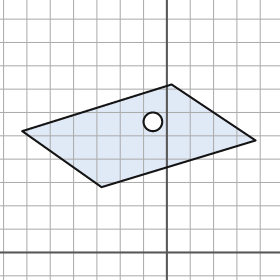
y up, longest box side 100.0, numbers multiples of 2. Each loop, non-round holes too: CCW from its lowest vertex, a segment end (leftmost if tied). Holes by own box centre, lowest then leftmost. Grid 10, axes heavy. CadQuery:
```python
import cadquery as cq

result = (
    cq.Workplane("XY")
    .moveTo(-28.0, 28.0)
    .lineTo(38.0, 48.0)
    .lineTo(2.0, 72.0)
    .lineTo(-62.0, 52.0)
    .close()
    .moveTo(-6.0, 56.0)
    .circle(4.0)
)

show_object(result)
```